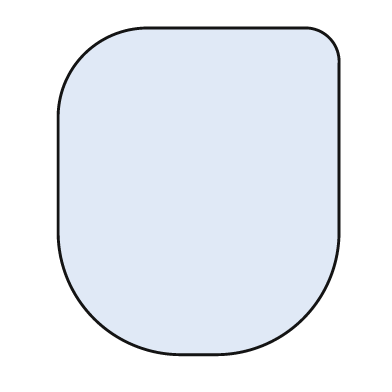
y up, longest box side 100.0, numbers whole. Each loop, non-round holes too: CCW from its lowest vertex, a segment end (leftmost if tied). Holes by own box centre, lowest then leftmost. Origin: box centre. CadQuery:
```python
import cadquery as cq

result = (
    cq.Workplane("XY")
    .moveTo(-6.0, -50.0)
    .lineTo(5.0, -50.0)
    .threePointArc((32.0, -39.0), (43.0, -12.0))
    .lineTo(43.0, 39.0)
    .threePointArc((40.0, 47.0), (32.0, 50.0))
    .lineTo(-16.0, 50.0)
    .threePointArc((-35.0, 42.0), (-43.0, 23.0))
    .lineTo(-43.0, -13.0)
    .threePointArc((-32.0, -39.0), (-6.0, -50.0))
    .close()
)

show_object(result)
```